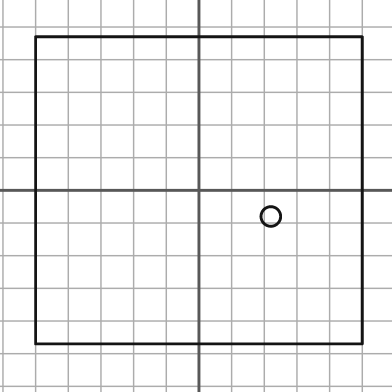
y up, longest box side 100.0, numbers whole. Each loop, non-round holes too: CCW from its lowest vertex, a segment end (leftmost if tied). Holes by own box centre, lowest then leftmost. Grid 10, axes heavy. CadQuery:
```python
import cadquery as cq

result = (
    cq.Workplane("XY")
    .moveTo(-50.0, -47.0)
    .lineTo(50.0, -47.0)
    .lineTo(50.0, 47.0)
    .lineTo(-50.0, 47.0)
    .close()
    .moveTo(22.0, -8.0)
    .circle(3.0)
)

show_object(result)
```